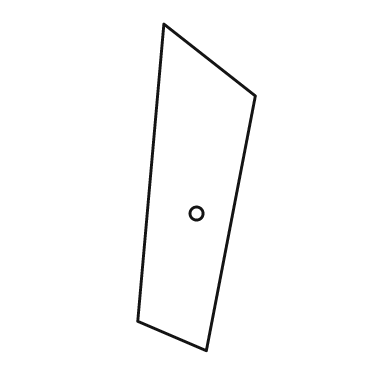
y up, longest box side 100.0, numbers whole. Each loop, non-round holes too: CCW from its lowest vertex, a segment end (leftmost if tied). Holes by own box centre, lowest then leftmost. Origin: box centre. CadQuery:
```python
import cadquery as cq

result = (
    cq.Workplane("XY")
    .moveTo(3.0, -50.0)
    .lineTo(18.0, 28.0)
    .lineTo(-10.0, 50.0)
    .lineTo(-18.0, -41.0)
    .close()
    .moveTo(0.0, -8.0)
    .circle(2.0)
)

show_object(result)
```